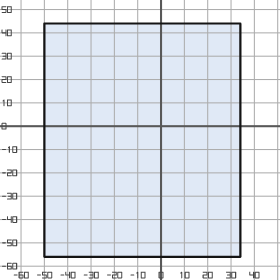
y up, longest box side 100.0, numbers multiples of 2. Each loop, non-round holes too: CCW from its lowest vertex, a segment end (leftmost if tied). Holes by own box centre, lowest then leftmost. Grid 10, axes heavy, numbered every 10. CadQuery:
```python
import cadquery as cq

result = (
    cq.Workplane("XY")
    .moveTo(-50.0, -56.0)
    .lineTo(34.0, -56.0)
    .lineTo(34.0, 44.0)
    .lineTo(-50.0, 44.0)
    .close()
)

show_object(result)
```